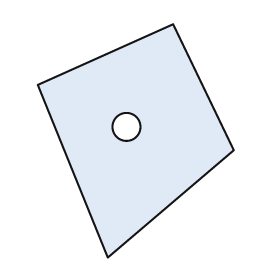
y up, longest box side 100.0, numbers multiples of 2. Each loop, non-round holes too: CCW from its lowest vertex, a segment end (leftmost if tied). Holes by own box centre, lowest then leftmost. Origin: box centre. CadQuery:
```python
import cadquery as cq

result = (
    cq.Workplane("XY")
    .moveTo(-12.0, -50.0)
    .lineTo(42.0, -4.0)
    .lineTo(16.0, 50.0)
    .lineTo(-42.0, 24.0)
    .close()
    .moveTo(-4.0, 6.0)
    .circle(6.0)
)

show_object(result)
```